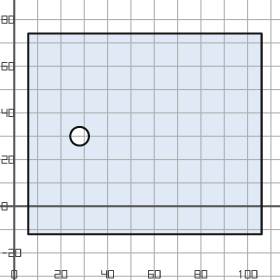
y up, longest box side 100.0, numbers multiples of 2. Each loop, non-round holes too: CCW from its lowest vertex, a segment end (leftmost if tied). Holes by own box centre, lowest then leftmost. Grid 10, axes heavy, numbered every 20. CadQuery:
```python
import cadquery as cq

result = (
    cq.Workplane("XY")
    .moveTo(6.0, -12.0)
    .lineTo(106.0, -12.0)
    .lineTo(106.0, 74.0)
    .lineTo(6.0, 74.0)
    .close()
    .moveTo(28.0, 30.0)
    .circle(4.0)
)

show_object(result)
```